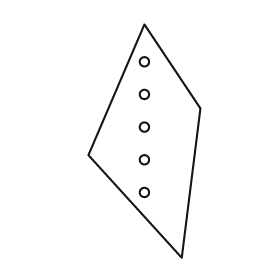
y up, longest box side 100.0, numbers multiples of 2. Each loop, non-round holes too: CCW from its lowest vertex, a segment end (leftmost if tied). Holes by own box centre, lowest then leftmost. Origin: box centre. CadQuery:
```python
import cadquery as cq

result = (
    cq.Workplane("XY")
    .moveTo(16.0, -50.0)
    .lineTo(24.0, 14.0)
    .lineTo(0.0, 50.0)
    .lineTo(-24.0, -6.0)
    .close()
    .moveTo(0.0, -22.0)
    .circle(2.0)
    .moveTo(0.0, -8.0)
    .circle(2.0)
    .moveTo(0.0, 6.0)
    .circle(2.0)
    .moveTo(0.0, 20.0)
    .circle(2.0)
    .moveTo(0.0, 34.0)
    .circle(2.0)
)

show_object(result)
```